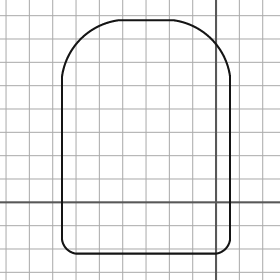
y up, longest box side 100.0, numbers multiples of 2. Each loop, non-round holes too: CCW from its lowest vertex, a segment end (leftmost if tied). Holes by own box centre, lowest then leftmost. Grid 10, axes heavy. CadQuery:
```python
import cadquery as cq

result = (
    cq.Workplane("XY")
    .moveTo(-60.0, -22.0)
    .lineTo(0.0, -22.0)
    .threePointArc((4.0, -20.0), (6.0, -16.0))
    .lineTo(6.0, 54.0)
    .threePointArc((-2.0, 70.0), (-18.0, 78.0))
    .lineTo(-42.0, 78.0)
    .threePointArc((-58.0, 70.0), (-66.0, 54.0))
    .lineTo(-66.0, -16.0)
    .threePointArc((-64.0, -20.0), (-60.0, -22.0))
    .close()
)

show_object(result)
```